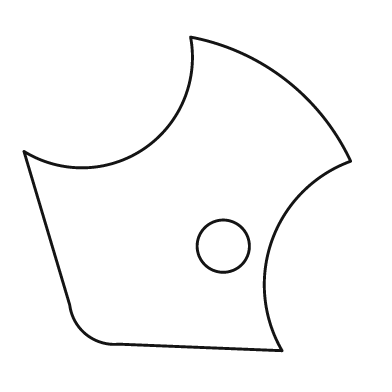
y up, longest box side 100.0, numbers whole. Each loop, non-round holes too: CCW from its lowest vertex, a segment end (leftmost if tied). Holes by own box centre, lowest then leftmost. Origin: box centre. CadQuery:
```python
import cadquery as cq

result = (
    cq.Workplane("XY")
    .moveTo(29.0, -48.0)
    .threePointArc((26.0, -14.0), (50.0, 10.0))
    .threePointArc((30.0, 35.0), (1.0, 48.0))
    .threePointArc((-13.0, 14.0), (-50.0, 13.0))
    .lineTo(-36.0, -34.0)
    .threePointArc((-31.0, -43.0), (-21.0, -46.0))
    .close()
    .moveTo(11.0, -16.0)
    .circle(8.0)
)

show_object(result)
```